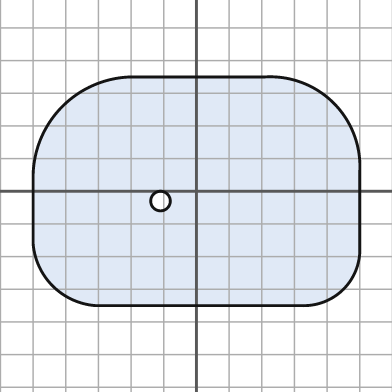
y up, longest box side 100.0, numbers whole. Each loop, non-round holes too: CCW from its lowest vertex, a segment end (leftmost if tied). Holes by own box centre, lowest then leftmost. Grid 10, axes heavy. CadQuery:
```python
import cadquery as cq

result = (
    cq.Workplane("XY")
    .moveTo(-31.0, -35.0)
    .lineTo(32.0, -35.0)
    .threePointArc((45.0, -30.0), (50.0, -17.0))
    .lineTo(50.0, 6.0)
    .threePointArc((42.0, 27.0), (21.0, 35.0))
    .lineTo(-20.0, 35.0)
    .threePointArc((-41.0, 26.0), (-50.0, 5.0))
    .lineTo(-50.0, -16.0)
    .threePointArc((-44.0, -29.0), (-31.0, -35.0))
    .close()
    .moveTo(-11.0, -3.0)
    .circle(3.0)
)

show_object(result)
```